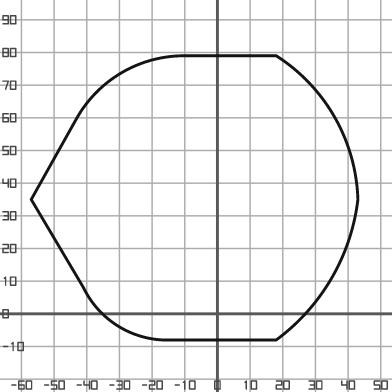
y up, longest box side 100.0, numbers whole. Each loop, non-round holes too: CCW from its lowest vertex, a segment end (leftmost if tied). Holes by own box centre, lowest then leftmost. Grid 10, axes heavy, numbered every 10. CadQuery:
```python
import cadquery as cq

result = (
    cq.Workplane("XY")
    .moveTo(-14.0, -8.0)
    .lineTo(18.0, -8.0)
    .threePointArc((35.0, 11.0), (43.0, 35.0))
    .threePointArc((36.0, 60.0), (18.0, 79.0))
    .lineTo(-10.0, 79.0)
    .threePointArc((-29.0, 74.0), (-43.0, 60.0))
    .lineTo(-57.0, 35.0)
    .lineTo(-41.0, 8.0)
    .threePointArc((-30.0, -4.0), (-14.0, -8.0))
    .close()
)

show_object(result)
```